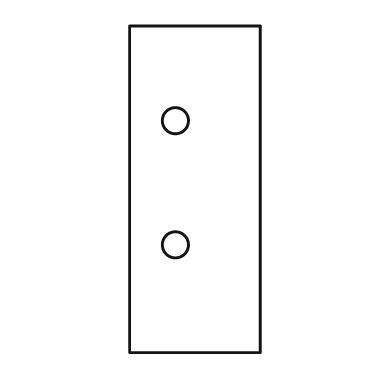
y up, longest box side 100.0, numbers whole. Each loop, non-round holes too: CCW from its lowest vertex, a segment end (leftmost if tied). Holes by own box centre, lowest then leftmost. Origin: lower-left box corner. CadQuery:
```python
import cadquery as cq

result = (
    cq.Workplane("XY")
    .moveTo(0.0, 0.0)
    .lineTo(40.0, 0.0)
    .lineTo(40.0, 100.0)
    .lineTo(0.0, 100.0)
    .close()
    .moveTo(14.0, 33.0)
    .circle(4.0)
    .moveTo(14.0, 71.0)
    .circle(4.0)
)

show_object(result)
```